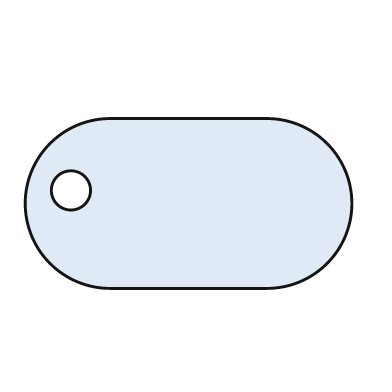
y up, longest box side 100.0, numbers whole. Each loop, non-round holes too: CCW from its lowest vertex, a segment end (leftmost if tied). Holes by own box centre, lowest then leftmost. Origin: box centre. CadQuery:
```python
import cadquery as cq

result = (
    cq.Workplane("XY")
    .moveTo(-24.0, -26.0)
    .lineTo(24.0, -26.0)
    .threePointArc((50.0, 0.0), (24.0, 26.0))
    .lineTo(-24.0, 26.0)
    .threePointArc((-50.0, 0.0), (-24.0, -26.0))
    .close()
    .moveTo(-36.0, 4.0)
    .circle(6.0)
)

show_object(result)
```